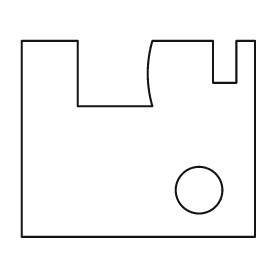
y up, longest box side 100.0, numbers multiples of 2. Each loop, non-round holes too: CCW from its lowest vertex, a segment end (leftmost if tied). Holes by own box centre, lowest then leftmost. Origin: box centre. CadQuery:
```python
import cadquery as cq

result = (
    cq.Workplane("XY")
    .moveTo(-50.0, -42.0)
    .lineTo(50.0, -42.0)
    .lineTo(50.0, 42.0)
    .lineTo(42.0, 42.0)
    .lineTo(42.0, 24.0)
    .lineTo(32.0, 24.0)
    .lineTo(32.0, 42.0)
    .lineTo(6.0, 42.0)
    .threePointArc((4.0, 28.0), (6.0, 14.0))
    .lineTo(-26.0, 14.0)
    .lineTo(-26.0, 42.0)
    .lineTo(-50.0, 42.0)
    .close()
    .moveTo(26.0, -22.0)
    .circle(10.0)
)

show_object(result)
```